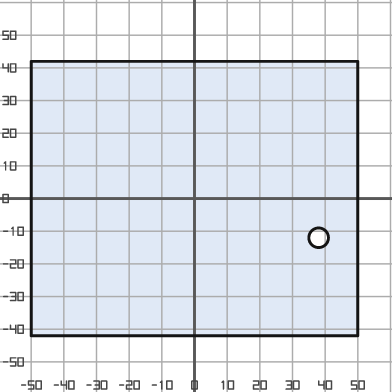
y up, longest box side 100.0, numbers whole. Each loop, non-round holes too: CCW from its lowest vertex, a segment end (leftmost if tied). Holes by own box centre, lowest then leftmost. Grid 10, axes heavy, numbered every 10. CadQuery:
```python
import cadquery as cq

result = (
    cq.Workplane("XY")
    .moveTo(-50.0, -42.0)
    .lineTo(50.0, -42.0)
    .lineTo(50.0, 42.0)
    .lineTo(-50.0, 42.0)
    .close()
    .moveTo(38.0, -12.0)
    .circle(3.0)
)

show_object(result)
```